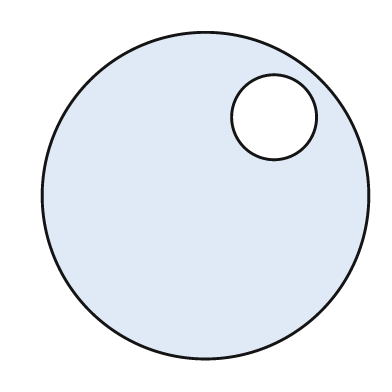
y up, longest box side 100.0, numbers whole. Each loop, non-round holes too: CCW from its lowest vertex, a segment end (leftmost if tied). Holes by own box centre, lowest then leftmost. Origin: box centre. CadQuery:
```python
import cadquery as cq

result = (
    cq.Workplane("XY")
    .moveTo(0.0, 0.0)
    .circle(50.0)
    .moveTo(21.0, 24.0)
    .circle(13.0)
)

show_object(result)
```